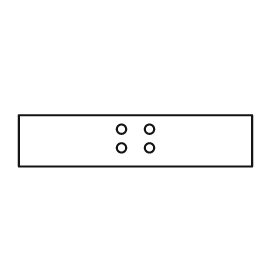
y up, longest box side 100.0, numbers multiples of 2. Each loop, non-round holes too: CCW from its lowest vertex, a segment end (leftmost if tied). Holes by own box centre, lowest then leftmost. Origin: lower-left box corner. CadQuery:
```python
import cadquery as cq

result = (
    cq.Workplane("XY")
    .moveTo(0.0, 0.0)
    .lineTo(100.0, 0.0)
    .lineTo(100.0, 22.0)
    .lineTo(0.0, 22.0)
    .close()
    .moveTo(44.0, 8.0)
    .circle(2.0)
    .moveTo(56.0, 8.0)
    .circle(2.0)
    .moveTo(44.0, 16.0)
    .circle(2.0)
    .moveTo(56.0, 16.0)
    .circle(2.0)
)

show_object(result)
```